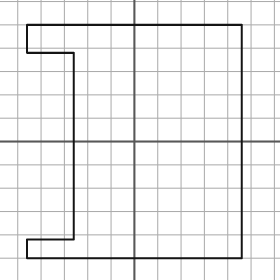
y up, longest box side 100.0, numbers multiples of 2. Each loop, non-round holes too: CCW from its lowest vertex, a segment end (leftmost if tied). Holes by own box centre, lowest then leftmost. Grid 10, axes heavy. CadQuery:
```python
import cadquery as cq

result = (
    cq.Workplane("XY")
    .moveTo(-46.0, -50.0)
    .lineTo(46.0, -50.0)
    .lineTo(46.0, 50.0)
    .lineTo(-46.0, 50.0)
    .lineTo(-46.0, 38.0)
    .lineTo(-26.0, 38.0)
    .lineTo(-26.0, -42.0)
    .lineTo(-46.0, -42.0)
    .close()
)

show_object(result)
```